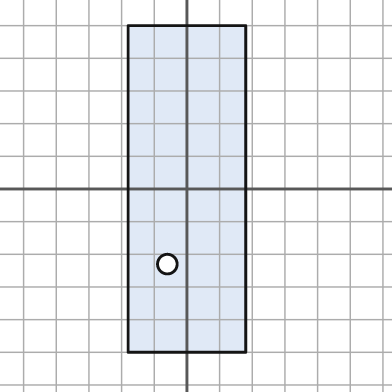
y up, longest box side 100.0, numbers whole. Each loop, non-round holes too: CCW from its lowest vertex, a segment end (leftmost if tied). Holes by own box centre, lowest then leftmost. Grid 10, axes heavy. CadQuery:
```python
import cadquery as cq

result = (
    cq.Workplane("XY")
    .moveTo(-18.0, -50.0)
    .lineTo(18.0, -50.0)
    .lineTo(18.0, 50.0)
    .lineTo(-18.0, 50.0)
    .close()
    .moveTo(-6.0, -23.0)
    .circle(3.0)
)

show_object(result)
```